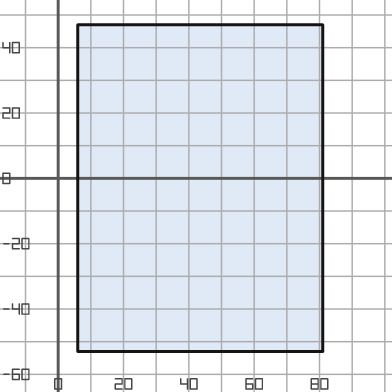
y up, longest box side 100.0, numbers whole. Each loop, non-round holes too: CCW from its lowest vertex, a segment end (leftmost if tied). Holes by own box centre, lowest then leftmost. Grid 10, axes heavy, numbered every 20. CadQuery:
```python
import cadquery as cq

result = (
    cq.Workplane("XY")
    .moveTo(6.0, -53.0)
    .lineTo(81.0, -53.0)
    .lineTo(81.0, 47.0)
    .lineTo(6.0, 47.0)
    .close()
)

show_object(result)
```